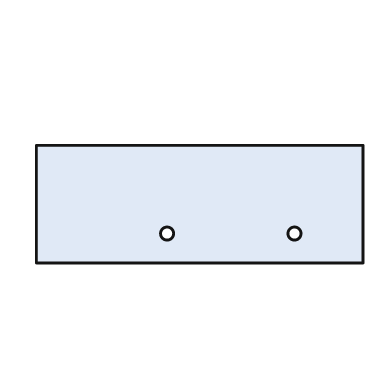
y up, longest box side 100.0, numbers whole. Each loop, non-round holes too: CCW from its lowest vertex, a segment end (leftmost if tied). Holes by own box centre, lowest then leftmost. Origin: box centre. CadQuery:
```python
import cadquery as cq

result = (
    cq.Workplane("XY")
    .moveTo(-50.0, -18.0)
    .lineTo(50.0, -18.0)
    .lineTo(50.0, 18.0)
    .lineTo(-50.0, 18.0)
    .close()
    .moveTo(-10.0, -9.0)
    .circle(2.0)
    .moveTo(29.0, -9.0)
    .circle(2.0)
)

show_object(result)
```